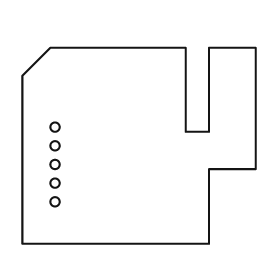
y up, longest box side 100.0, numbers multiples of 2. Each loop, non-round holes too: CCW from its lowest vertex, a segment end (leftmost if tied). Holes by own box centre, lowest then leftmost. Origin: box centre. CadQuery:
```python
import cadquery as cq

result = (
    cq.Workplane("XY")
    .moveTo(-50.0, -42.0)
    .lineTo(30.0, -42.0)
    .lineTo(30.0, -10.0)
    .lineTo(50.0, -10.0)
    .lineTo(50.0, 42.0)
    .lineTo(30.0, 42.0)
    .lineTo(30.0, 6.0)
    .lineTo(20.0, 6.0)
    .lineTo(20.0, 42.0)
    .lineTo(-38.0, 42.0)
    .lineTo(-50.0, 30.0)
    .close()
    .moveTo(-36.0, -24.0)
    .circle(2.0)
    .moveTo(-36.0, -16.0)
    .circle(2.0)
    .moveTo(-36.0, -8.0)
    .circle(2.0)
    .moveTo(-36.0, 0.0)
    .circle(2.0)
    .moveTo(-36.0, 8.0)
    .circle(2.0)
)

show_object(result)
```